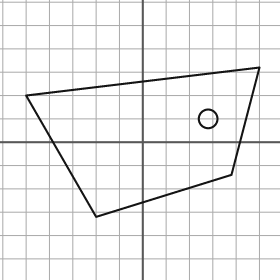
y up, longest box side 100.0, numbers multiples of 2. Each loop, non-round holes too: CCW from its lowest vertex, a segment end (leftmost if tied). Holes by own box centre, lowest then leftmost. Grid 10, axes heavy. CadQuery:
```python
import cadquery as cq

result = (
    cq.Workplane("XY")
    .moveTo(-20.0, -32.0)
    .lineTo(38.0, -14.0)
    .lineTo(50.0, 32.0)
    .lineTo(-50.0, 20.0)
    .close()
    .moveTo(28.0, 10.0)
    .circle(4.0)
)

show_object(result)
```